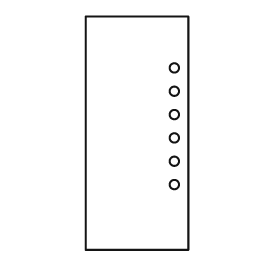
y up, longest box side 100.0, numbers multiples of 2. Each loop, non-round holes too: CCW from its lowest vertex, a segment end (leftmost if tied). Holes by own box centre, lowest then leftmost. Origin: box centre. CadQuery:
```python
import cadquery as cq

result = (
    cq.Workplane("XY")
    .moveTo(-22.0, -50.0)
    .lineTo(22.0, -50.0)
    .lineTo(22.0, 50.0)
    .lineTo(-22.0, 50.0)
    .close()
    .moveTo(16.0, -22.0)
    .circle(2.0)
    .moveTo(16.0, -12.0)
    .circle(2.0)
    .moveTo(16.0, -2.0)
    .circle(2.0)
    .moveTo(16.0, 8.0)
    .circle(2.0)
    .moveTo(16.0, 18.0)
    .circle(2.0)
    .moveTo(16.0, 28.0)
    .circle(2.0)
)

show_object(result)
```